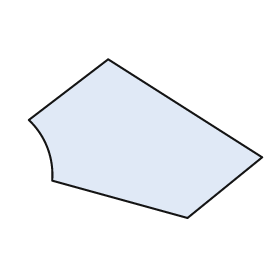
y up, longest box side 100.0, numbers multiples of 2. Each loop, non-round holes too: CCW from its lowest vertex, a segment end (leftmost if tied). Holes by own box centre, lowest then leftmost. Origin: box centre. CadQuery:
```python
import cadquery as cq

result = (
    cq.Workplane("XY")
    .moveTo(18.0, -34.0)
    .lineTo(50.0, -8.0)
    .lineTo(-16.0, 34.0)
    .lineTo(-50.0, 8.0)
    .threePointArc((-42.0, -4.0), (-40.0, -18.0))
    .close()
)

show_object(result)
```